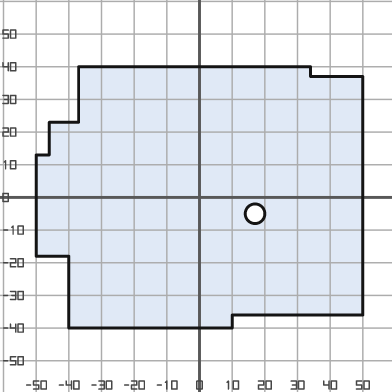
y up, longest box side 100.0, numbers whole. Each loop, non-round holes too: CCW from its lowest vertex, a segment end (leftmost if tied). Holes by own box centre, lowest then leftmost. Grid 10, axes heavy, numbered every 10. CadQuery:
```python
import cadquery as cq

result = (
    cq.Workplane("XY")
    .moveTo(-40.0, -40.0)
    .lineTo(10.0, -40.0)
    .lineTo(10.0, -36.0)
    .lineTo(50.0, -36.0)
    .lineTo(50.0, 37.0)
    .lineTo(34.0, 37.0)
    .lineTo(34.0, 40.0)
    .lineTo(-37.0, 40.0)
    .lineTo(-37.0, 23.0)
    .lineTo(-46.0, 23.0)
    .lineTo(-46.0, 13.0)
    .lineTo(-50.0, 13.0)
    .lineTo(-50.0, -18.0)
    .lineTo(-40.0, -18.0)
    .close()
    .moveTo(17.0, -5.0)
    .circle(3.0)
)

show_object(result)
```